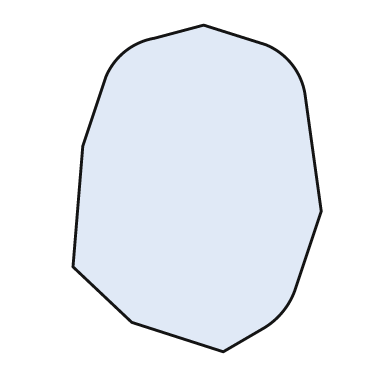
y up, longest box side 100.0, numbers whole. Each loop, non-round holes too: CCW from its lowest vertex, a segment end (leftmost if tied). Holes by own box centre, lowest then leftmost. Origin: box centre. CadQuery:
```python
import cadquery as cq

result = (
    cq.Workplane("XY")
    .moveTo(8.0, -50.0)
    .lineTo(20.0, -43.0)
    .threePointArc((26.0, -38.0), (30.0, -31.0))
    .lineTo(38.0, -7.0)
    .lineTo(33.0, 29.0)
    .threePointArc((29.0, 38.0), (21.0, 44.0))
    .lineTo(2.0, 50.0)
    .lineTo(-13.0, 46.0)
    .threePointArc((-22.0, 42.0), (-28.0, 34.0))
    .lineTo(-35.0, 13.0)
    .lineTo(-38.0, -24.0)
    .lineTo(-20.0, -41.0)
    .close()
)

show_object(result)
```